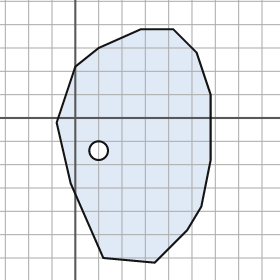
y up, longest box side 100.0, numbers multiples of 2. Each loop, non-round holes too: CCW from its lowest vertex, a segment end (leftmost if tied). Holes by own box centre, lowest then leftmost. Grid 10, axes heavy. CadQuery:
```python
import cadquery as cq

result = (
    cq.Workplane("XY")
    .moveTo(34.0, -62.0)
    .lineTo(48.0, -48.0)
    .lineTo(54.0, -38.0)
    .lineTo(58.0, -18.0)
    .lineTo(58.0, 10.0)
    .lineTo(52.0, 28.0)
    .lineTo(42.0, 38.0)
    .lineTo(28.0, 38.0)
    .lineTo(10.0, 30.0)
    .lineTo(0.0, 22.0)
    .lineTo(-8.0, -2.0)
    .lineTo(-2.0, -28.0)
    .lineTo(12.0, -60.0)
    .close()
    .moveTo(10.0, -14.0)
    .circle(4.0)
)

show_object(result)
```